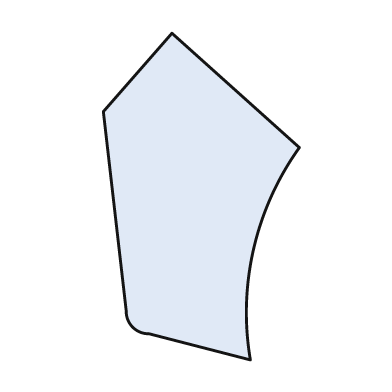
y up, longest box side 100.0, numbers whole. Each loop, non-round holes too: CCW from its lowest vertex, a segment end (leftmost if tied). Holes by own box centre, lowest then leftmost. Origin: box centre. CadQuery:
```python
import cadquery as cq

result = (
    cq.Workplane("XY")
    .moveTo(15.0, -50.0)
    .threePointArc((16.0, -16.0), (30.0, 15.0))
    .lineTo(-9.0, 50.0)
    .lineTo(-30.0, 26.0)
    .lineTo(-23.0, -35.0)
    .threePointArc((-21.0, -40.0), (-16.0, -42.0))
    .close()
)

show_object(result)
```